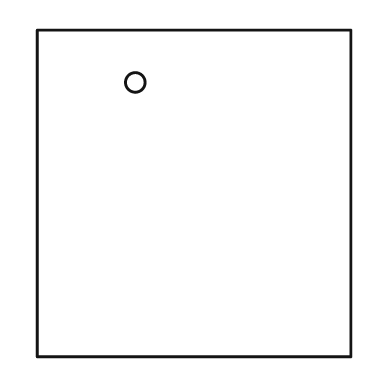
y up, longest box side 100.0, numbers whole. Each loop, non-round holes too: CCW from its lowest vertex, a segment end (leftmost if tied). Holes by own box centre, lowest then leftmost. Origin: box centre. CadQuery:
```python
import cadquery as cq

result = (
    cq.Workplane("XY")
    .moveTo(-48.0, -50.0)
    .lineTo(48.0, -50.0)
    .lineTo(48.0, 50.0)
    .lineTo(-48.0, 50.0)
    .close()
    .moveTo(-18.0, 34.0)
    .circle(3.0)
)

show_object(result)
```